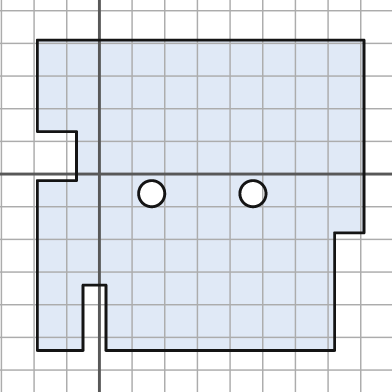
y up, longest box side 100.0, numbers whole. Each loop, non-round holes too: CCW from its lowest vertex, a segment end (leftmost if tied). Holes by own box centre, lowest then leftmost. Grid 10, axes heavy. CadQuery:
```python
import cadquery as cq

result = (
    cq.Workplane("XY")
    .moveTo(-19.0, -54.0)
    .lineTo(-5.0, -54.0)
    .lineTo(-5.0, -34.0)
    .lineTo(2.0, -34.0)
    .lineTo(2.0, -54.0)
    .lineTo(72.0, -54.0)
    .lineTo(72.0, -18.0)
    .lineTo(81.0, -18.0)
    .lineTo(81.0, 41.0)
    .lineTo(-19.0, 41.0)
    .lineTo(-19.0, 13.0)
    .lineTo(-7.0, 13.0)
    .lineTo(-7.0, -2.0)
    .lineTo(-19.0, -2.0)
    .close()
    .moveTo(16.0, -6.0)
    .circle(4.0)
    .moveTo(47.0, -6.0)
    .circle(4.0)
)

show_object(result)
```